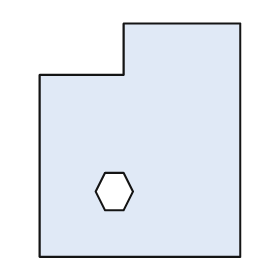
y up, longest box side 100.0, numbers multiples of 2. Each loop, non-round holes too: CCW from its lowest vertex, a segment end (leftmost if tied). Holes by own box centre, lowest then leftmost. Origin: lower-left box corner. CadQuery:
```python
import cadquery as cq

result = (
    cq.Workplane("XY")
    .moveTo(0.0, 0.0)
    .lineTo(86.0, 0.0)
    .lineTo(86.0, 100.0)
    .lineTo(36.0, 100.0)
    .lineTo(36.0, 78.0)
    .lineTo(0.0, 78.0)
    .close()
    .moveTo(28.0, 20.0)
    .lineTo(36.0, 20.0)
    .lineTo(40.0, 28.0)
    .lineTo(36.0, 36.0)
    .lineTo(28.0, 36.0)
    .lineTo(24.0, 28.0)
    .close()
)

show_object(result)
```